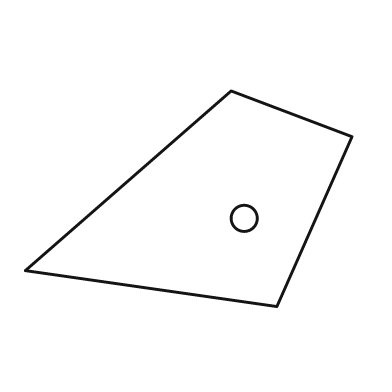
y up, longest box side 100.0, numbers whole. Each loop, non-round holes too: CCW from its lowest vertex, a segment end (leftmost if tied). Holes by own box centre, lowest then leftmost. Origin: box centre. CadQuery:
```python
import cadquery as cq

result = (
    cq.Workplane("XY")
    .moveTo(27.0, -33.0)
    .lineTo(50.0, 19.0)
    .lineTo(13.0, 33.0)
    .lineTo(-50.0, -22.0)
    .close()
    .moveTo(17.0, -6.0)
    .circle(4.0)
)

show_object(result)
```